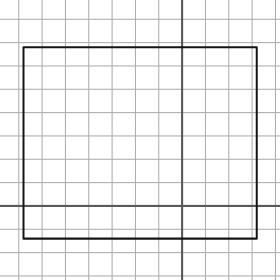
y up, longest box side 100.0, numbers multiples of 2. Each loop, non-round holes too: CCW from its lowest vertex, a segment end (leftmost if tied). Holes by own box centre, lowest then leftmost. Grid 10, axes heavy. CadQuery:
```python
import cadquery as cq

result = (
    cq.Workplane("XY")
    .moveTo(-68.0, -14.0)
    .lineTo(32.0, -14.0)
    .lineTo(32.0, 68.0)
    .lineTo(-68.0, 68.0)
    .close()
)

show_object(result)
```